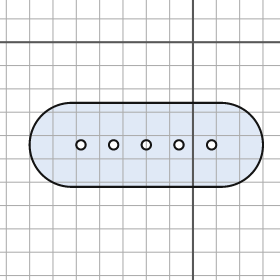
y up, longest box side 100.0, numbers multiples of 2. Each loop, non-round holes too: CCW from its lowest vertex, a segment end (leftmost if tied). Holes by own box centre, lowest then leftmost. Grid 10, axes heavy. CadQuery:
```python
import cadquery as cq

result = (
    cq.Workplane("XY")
    .moveTo(-52.0, -62.0)
    .lineTo(12.0, -62.0)
    .threePointArc((30.0, -44.0), (12.0, -26.0))
    .lineTo(-52.0, -26.0)
    .threePointArc((-70.0, -44.0), (-52.0, -62.0))
    .close()
    .moveTo(-48.0, -44.0)
    .circle(2.0)
    .moveTo(-34.0, -44.0)
    .circle(2.0)
    .moveTo(-20.0, -44.0)
    .circle(2.0)
    .moveTo(-6.0, -44.0)
    .circle(2.0)
    .moveTo(8.0, -44.0)
    .circle(2.0)
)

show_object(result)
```